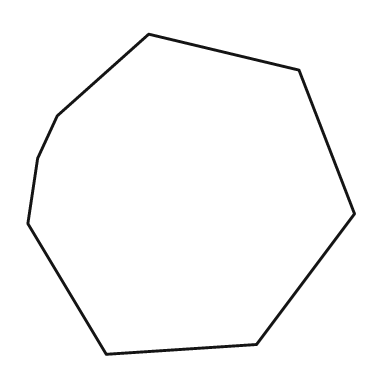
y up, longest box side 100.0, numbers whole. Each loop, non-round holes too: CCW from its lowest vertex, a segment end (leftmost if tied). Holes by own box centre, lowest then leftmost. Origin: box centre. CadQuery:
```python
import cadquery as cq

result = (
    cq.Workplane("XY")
    .moveTo(-26.0, -49.0)
    .lineTo(20.0, -46.0)
    .lineTo(50.0, -6.0)
    .lineTo(33.0, 38.0)
    .lineTo(-13.0, 49.0)
    .lineTo(-41.0, 24.0)
    .lineTo(-47.0, 11.0)
    .lineTo(-50.0, -9.0)
    .close()
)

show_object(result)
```